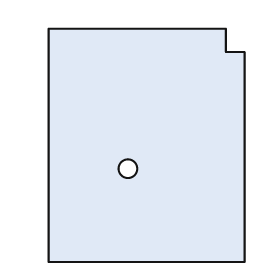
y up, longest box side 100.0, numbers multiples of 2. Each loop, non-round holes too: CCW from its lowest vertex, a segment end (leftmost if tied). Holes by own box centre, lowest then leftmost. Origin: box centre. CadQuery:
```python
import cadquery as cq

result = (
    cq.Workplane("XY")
    .moveTo(-42.0, -50.0)
    .lineTo(42.0, -50.0)
    .lineTo(42.0, 40.0)
    .lineTo(34.0, 40.0)
    .lineTo(34.0, 50.0)
    .lineTo(-42.0, 50.0)
    .close()
    .moveTo(-8.0, -10.0)
    .circle(4.0)
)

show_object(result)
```